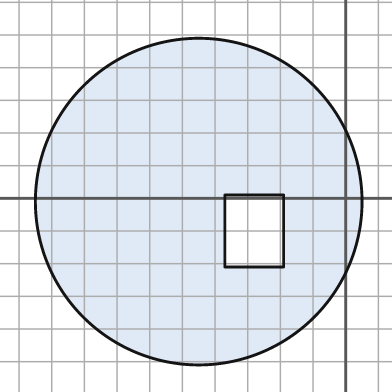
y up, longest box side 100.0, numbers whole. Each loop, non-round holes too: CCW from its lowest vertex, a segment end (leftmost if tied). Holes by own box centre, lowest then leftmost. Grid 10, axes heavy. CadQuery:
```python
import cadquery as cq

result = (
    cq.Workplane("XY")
    .moveTo(-45.0, -1.0)
    .circle(50.0)
    .moveTo(-37.0, -21.0)
    .lineTo(-19.0, -21.0)
    .lineTo(-19.0, 1.0)
    .lineTo(-37.0, 1.0)
    .close()
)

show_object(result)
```